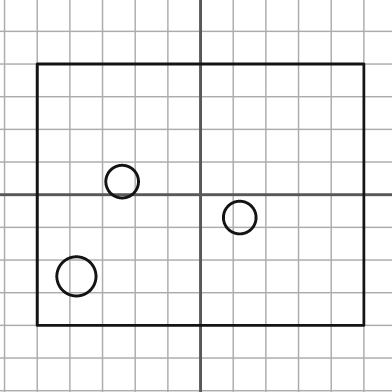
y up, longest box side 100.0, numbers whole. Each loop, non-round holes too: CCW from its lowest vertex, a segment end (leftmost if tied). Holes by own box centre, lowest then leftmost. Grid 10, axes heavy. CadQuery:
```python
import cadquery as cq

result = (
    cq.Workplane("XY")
    .moveTo(-50.0, -40.0)
    .lineTo(50.0, -40.0)
    .lineTo(50.0, 40.0)
    .lineTo(-50.0, 40.0)
    .close()
    .moveTo(-38.0, -25.0)
    .circle(6.0)
    .moveTo(12.0, -7.0)
    .circle(5.0)
    .moveTo(-24.0, 4.0)
    .circle(5.0)
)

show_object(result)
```